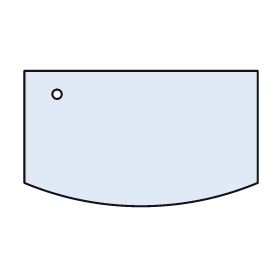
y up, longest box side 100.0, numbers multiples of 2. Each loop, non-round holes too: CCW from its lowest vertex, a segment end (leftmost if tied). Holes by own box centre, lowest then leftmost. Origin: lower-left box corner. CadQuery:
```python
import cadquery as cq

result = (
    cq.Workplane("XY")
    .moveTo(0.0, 10.0)
    .threePointArc((50.0, 0.0), (100.0, 10.0))
    .lineTo(100.0, 58.0)
    .lineTo(0.0, 58.0)
    .close()
    .moveTo(14.0, 48.0)
    .circle(2.0)
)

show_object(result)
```